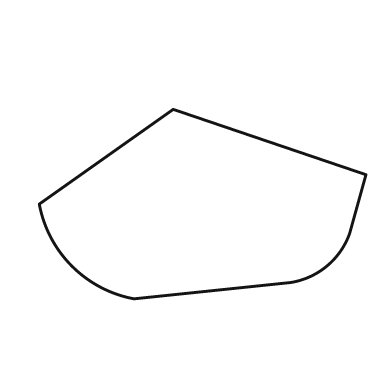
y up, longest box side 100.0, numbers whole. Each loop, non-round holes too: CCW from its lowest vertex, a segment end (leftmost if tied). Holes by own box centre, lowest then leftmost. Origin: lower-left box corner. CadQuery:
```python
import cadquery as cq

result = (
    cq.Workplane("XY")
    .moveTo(29.0, 0.0)
    .lineTo(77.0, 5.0)
    .threePointArc((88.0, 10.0), (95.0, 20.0))
    .lineTo(100.0, 38.0)
    .lineTo(41.0, 58.0)
    .lineTo(0.0, 29.0)
    .threePointArc((10.0, 10.0), (29.0, 0.0))
    .close()
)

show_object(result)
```